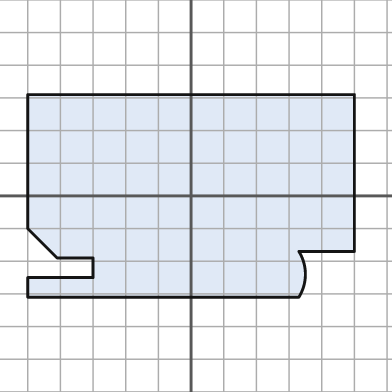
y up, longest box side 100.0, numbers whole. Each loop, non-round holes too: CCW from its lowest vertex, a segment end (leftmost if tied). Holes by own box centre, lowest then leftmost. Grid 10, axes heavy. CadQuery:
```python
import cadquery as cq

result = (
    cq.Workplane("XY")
    .moveTo(-50.0, -31.0)
    .lineTo(33.0, -31.0)
    .threePointArc((35.0, -24.0), (33.0, -17.0))
    .lineTo(50.0, -17.0)
    .lineTo(50.0, 31.0)
    .lineTo(-50.0, 31.0)
    .lineTo(-50.0, -10.0)
    .lineTo(-41.0, -19.0)
    .lineTo(-30.0, -19.0)
    .lineTo(-30.0, -25.0)
    .lineTo(-50.0, -25.0)
    .close()
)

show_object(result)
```